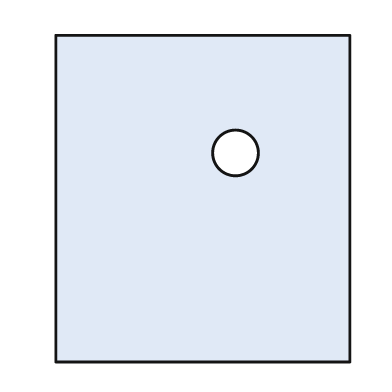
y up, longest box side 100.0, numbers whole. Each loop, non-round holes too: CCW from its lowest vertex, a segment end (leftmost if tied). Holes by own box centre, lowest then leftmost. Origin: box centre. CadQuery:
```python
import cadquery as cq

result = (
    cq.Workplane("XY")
    .moveTo(-45.0, -50.0)
    .lineTo(45.0, -50.0)
    .lineTo(45.0, 50.0)
    .lineTo(-45.0, 50.0)
    .close()
    .moveTo(10.0, 14.0)
    .circle(7.0)
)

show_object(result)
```